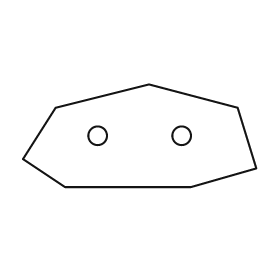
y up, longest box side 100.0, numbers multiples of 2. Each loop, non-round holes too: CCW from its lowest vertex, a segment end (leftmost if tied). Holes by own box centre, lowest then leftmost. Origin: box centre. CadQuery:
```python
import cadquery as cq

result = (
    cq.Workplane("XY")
    .moveTo(-32.0, -22.0)
    .lineTo(22.0, -22.0)
    .lineTo(50.0, -14.0)
    .lineTo(42.0, 12.0)
    .lineTo(4.0, 22.0)
    .lineTo(-36.0, 12.0)
    .lineTo(-50.0, -10.0)
    .close()
    .moveTo(-18.0, 0.0)
    .circle(4.0)
    .moveTo(18.0, 0.0)
    .circle(4.0)
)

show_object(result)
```